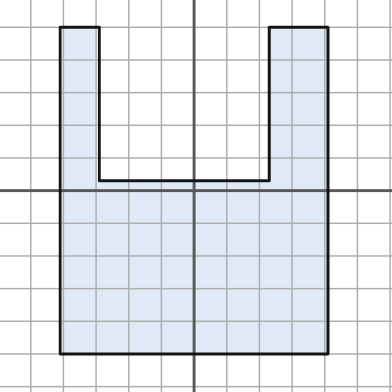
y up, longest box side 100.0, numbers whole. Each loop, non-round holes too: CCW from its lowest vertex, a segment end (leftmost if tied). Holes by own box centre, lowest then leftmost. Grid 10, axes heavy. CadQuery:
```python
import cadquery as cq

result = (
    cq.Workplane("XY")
    .moveTo(-41.0, -50.0)
    .lineTo(41.0, -50.0)
    .lineTo(41.0, 50.0)
    .lineTo(23.0, 50.0)
    .lineTo(23.0, 3.0)
    .lineTo(-29.0, 3.0)
    .lineTo(-29.0, 50.0)
    .lineTo(-41.0, 50.0)
    .close()
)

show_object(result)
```